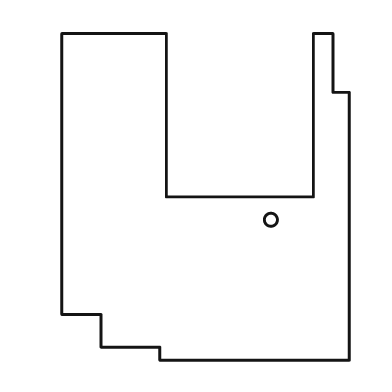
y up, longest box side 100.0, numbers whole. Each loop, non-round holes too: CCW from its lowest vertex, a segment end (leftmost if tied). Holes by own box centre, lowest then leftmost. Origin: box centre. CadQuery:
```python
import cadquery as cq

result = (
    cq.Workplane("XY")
    .moveTo(-14.0, -50.0)
    .lineTo(44.0, -50.0)
    .lineTo(44.0, 32.0)
    .lineTo(39.0, 32.0)
    .lineTo(39.0, 50.0)
    .lineTo(33.0, 50.0)
    .lineTo(33.0, 0.0)
    .lineTo(-12.0, 0.0)
    .lineTo(-12.0, 50.0)
    .lineTo(-44.0, 50.0)
    .lineTo(-44.0, -36.0)
    .lineTo(-32.0, -36.0)
    .lineTo(-32.0, -46.0)
    .lineTo(-14.0, -46.0)
    .close()
    .moveTo(20.0, -7.0)
    .circle(2.0)
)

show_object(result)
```